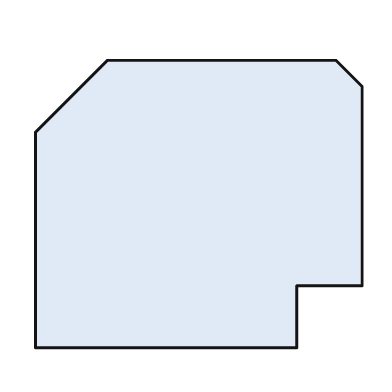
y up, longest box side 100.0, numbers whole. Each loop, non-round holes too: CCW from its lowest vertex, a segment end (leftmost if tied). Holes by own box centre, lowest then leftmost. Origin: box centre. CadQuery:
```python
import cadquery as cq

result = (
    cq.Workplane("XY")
    .moveTo(-50.0, -44.0)
    .lineTo(30.0, -44.0)
    .lineTo(30.0, -25.0)
    .lineTo(50.0, -25.0)
    .lineTo(50.0, 36.0)
    .lineTo(42.0, 44.0)
    .lineTo(-28.0, 44.0)
    .lineTo(-50.0, 22.0)
    .close()
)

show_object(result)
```